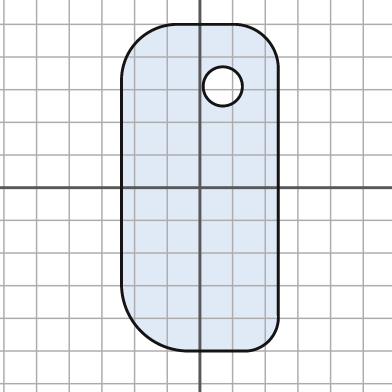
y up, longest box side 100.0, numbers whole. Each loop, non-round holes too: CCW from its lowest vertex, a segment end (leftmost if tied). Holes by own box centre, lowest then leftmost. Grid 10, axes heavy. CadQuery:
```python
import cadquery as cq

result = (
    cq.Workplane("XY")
    .moveTo(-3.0, -50.0)
    .lineTo(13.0, -50.0)
    .threePointArc((21.0, -47.0), (24.0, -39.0))
    .lineTo(24.0, 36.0)
    .threePointArc((20.0, 46.0), (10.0, 50.0))
    .lineTo(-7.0, 50.0)
    .threePointArc((-19.0, 45.0), (-24.0, 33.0))
    .lineTo(-24.0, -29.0)
    .threePointArc((-18.0, -44.0), (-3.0, -50.0))
    .close()
    .moveTo(7.0, 31.0)
    .circle(6.0)
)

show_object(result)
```